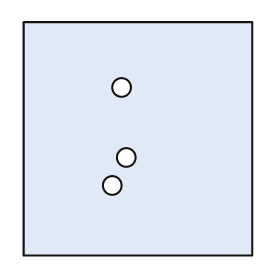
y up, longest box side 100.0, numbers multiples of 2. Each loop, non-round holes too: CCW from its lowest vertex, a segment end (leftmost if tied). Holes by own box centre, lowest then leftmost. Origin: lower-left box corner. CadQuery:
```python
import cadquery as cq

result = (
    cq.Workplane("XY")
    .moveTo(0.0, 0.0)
    .lineTo(98.0, 0.0)
    .lineTo(98.0, 100.0)
    .lineTo(0.0, 100.0)
    .close()
    .moveTo(38.0, 30.0)
    .circle(4.0)
    .moveTo(44.0, 42.0)
    .circle(4.0)
    .moveTo(42.0, 72.0)
    .circle(4.0)
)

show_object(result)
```